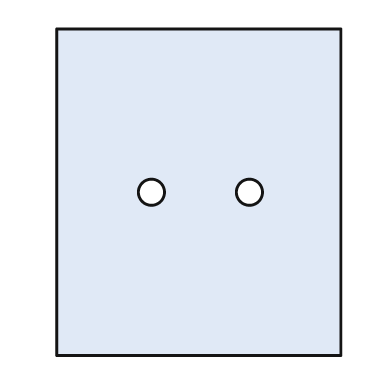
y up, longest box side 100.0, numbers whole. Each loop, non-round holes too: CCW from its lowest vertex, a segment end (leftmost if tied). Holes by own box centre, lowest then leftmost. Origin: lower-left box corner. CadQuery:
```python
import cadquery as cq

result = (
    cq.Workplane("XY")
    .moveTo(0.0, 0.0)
    .lineTo(87.0, 0.0)
    .lineTo(87.0, 100.0)
    .lineTo(0.0, 100.0)
    .close()
    .moveTo(29.0, 50.0)
    .circle(4.0)
    .moveTo(59.0, 50.0)
    .circle(4.0)
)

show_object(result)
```